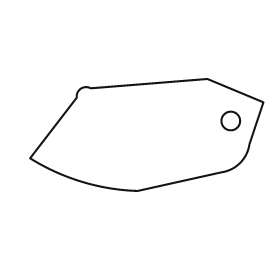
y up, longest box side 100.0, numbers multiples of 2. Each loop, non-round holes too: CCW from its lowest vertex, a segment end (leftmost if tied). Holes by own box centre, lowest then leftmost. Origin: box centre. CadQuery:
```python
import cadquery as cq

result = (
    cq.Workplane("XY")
    .moveTo(-4.0, -24.0)
    .lineTo(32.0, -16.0)
    .threePointArc((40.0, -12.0), (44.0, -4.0))
    .lineTo(50.0, 14.0)
    .lineTo(26.0, 24.0)
    .lineTo(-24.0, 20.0)
    .threePointArc((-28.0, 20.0), (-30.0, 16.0))
    .lineTo(-50.0, -10.0)
    .threePointArc((-28.0, -20.0), (-4.0, -24.0))
    .close()
    .moveTo(36.0, 6.0)
    .circle(4.0)
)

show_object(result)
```